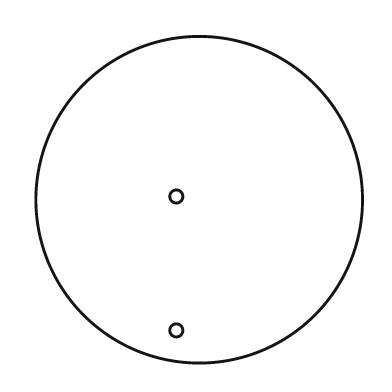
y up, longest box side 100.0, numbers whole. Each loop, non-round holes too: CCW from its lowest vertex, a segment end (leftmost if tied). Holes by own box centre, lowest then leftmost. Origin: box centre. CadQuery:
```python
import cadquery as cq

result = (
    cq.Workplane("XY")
    .moveTo(0.0, 0.0)
    .circle(50.0)
    .moveTo(-7.0, -40.0)
    .circle(2.0)
    .moveTo(-7.0, 1.0)
    .circle(2.0)
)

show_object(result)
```